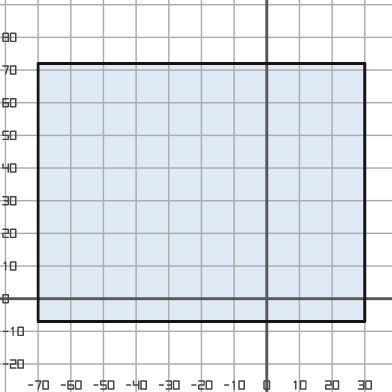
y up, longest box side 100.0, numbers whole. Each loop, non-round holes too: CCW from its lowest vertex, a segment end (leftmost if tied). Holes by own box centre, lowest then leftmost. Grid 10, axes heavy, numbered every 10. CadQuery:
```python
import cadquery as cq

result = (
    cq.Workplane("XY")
    .moveTo(-70.0, -7.0)
    .lineTo(30.0, -7.0)
    .lineTo(30.0, 72.0)
    .lineTo(-70.0, 72.0)
    .close()
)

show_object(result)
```